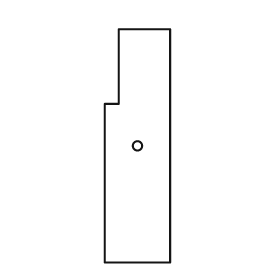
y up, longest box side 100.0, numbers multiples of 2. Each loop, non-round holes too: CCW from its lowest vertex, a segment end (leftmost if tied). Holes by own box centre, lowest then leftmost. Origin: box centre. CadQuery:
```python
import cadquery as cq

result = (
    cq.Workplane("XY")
    .moveTo(-14.0, -50.0)
    .lineTo(14.0, -50.0)
    .lineTo(14.0, 50.0)
    .lineTo(-8.0, 50.0)
    .lineTo(-8.0, 18.0)
    .lineTo(-14.0, 18.0)
    .close()
    .moveTo(0.0, 0.0)
    .circle(2.0)
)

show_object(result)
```